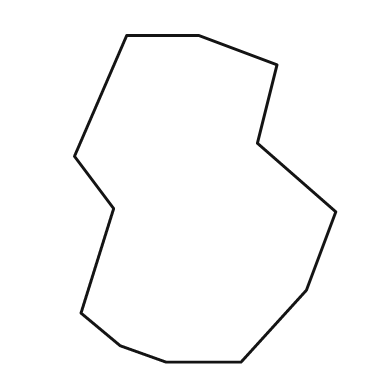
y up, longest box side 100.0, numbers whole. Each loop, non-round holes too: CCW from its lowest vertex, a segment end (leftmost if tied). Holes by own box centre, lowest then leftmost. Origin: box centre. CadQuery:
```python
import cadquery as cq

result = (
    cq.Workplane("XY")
    .moveTo(-12.0, -50.0)
    .lineTo(11.0, -50.0)
    .lineTo(31.0, -28.0)
    .lineTo(40.0, -4.0)
    .lineTo(16.0, 17.0)
    .lineTo(22.0, 41.0)
    .lineTo(-2.0, 50.0)
    .lineTo(-24.0, 50.0)
    .lineTo(-40.0, 13.0)
    .lineTo(-28.0, -3.0)
    .lineTo(-38.0, -35.0)
    .lineTo(-26.0, -45.0)
    .close()
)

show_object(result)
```